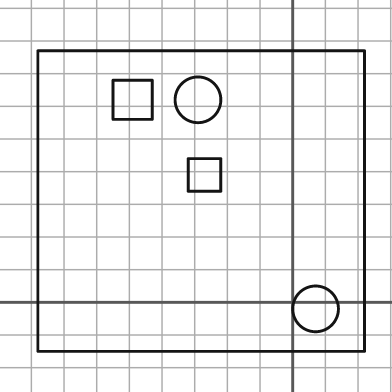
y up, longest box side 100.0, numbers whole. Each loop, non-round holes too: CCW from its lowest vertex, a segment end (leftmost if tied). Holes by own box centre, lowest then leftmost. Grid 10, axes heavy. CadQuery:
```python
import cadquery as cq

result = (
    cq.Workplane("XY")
    .moveTo(-78.0, -15.0)
    .lineTo(22.0, -15.0)
    .lineTo(22.0, 77.0)
    .lineTo(-78.0, 77.0)
    .close()
    .moveTo(7.0, -2.0)
    .circle(7.0)
    .moveTo(-32.0, 34.0)
    .lineTo(-22.0, 34.0)
    .lineTo(-22.0, 44.0)
    .lineTo(-32.0, 44.0)
    .close()
    .moveTo(-55.0, 56.0)
    .lineTo(-43.0, 56.0)
    .lineTo(-43.0, 68.0)
    .lineTo(-55.0, 68.0)
    .close()
    .moveTo(-29.0, 62.0)
    .circle(7.0)
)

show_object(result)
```